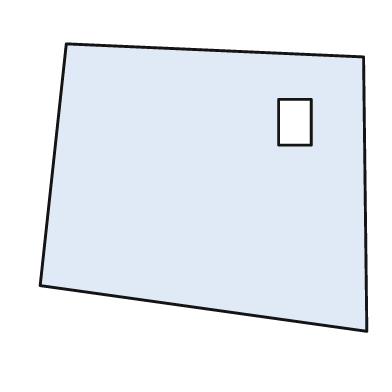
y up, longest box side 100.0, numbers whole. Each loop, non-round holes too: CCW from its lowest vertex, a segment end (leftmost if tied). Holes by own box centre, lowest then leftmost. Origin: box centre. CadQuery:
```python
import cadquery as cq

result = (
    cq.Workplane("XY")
    .moveTo(50.0, -44.0)
    .lineTo(49.0, 40.0)
    .lineTo(-42.0, 44.0)
    .lineTo(-50.0, -30.0)
    .close()
    .moveTo(23.0, 13.0)
    .lineTo(33.0, 13.0)
    .lineTo(33.0, 27.0)
    .lineTo(23.0, 27.0)
    .close()
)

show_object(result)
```